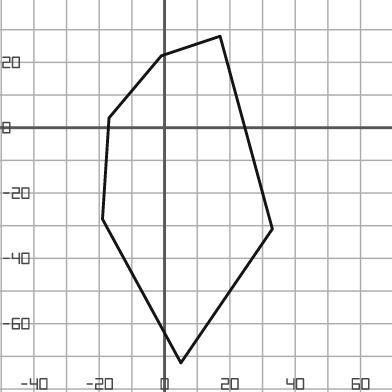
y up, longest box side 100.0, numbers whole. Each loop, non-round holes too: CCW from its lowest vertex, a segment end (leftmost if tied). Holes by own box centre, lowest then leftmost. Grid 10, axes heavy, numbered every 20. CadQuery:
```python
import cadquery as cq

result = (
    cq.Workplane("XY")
    .moveTo(5.0, -72.0)
    .lineTo(33.0, -31.0)
    .lineTo(17.0, 28.0)
    .lineTo(-1.0, 22.0)
    .lineTo(-17.0, 3.0)
    .lineTo(-19.0, -28.0)
    .close()
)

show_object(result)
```